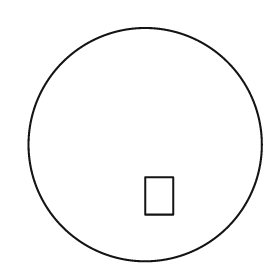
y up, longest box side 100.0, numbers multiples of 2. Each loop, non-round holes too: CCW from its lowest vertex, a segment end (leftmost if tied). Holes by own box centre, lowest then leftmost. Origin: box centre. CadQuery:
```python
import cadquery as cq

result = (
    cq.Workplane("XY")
    .moveTo(0.0, 0.0)
    .circle(50.0)
    .moveTo(0.0, -30.0)
    .lineTo(12.0, -30.0)
    .lineTo(12.0, -14.0)
    .lineTo(0.0, -14.0)
    .close()
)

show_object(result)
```